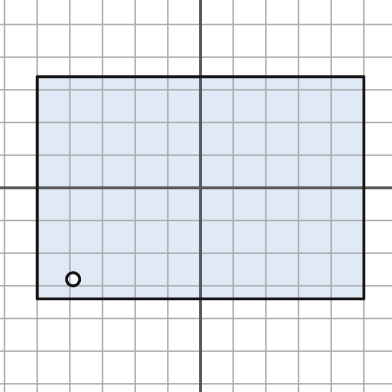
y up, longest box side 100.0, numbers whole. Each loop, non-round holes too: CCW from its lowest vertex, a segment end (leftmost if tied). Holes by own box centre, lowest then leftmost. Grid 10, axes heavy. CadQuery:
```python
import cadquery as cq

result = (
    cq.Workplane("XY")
    .moveTo(-50.0, -34.0)
    .lineTo(50.0, -34.0)
    .lineTo(50.0, 34.0)
    .lineTo(-50.0, 34.0)
    .close()
    .moveTo(-39.0, -28.0)
    .circle(2.0)
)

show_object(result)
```